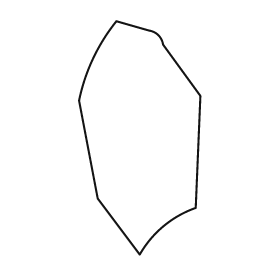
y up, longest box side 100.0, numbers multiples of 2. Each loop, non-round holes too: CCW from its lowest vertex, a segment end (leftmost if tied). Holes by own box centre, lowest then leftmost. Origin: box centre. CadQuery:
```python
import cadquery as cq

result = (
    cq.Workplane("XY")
    .moveTo(0.0, -50.0)
    .threePointArc((10.0, -38.0), (24.0, -30.0))
    .lineTo(26.0, 18.0)
    .lineTo(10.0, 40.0)
    .threePointArc((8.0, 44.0), (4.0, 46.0))
    .lineTo(-10.0, 50.0)
    .threePointArc((-20.0, 34.0), (-26.0, 16.0))
    .lineTo(-18.0, -26.0)
    .close()
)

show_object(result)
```